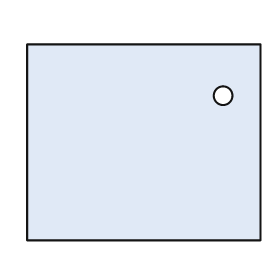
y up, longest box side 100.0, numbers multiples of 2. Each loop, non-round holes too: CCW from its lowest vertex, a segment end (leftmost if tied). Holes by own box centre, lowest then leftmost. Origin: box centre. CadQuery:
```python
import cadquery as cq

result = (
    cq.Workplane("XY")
    .moveTo(-50.0, -42.0)
    .lineTo(50.0, -42.0)
    .lineTo(50.0, 42.0)
    .lineTo(-50.0, 42.0)
    .close()
    .moveTo(34.0, 20.0)
    .circle(4.0)
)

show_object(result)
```